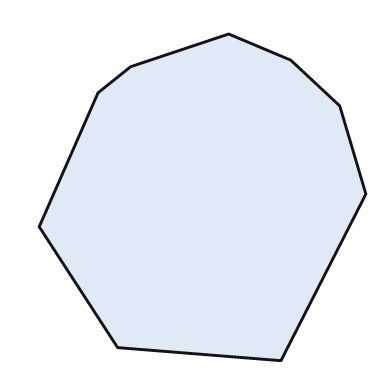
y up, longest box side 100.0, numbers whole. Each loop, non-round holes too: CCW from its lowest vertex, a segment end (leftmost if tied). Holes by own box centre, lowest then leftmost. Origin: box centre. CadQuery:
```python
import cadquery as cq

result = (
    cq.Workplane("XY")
    .moveTo(24.0, -50.0)
    .lineTo(50.0, 1.0)
    .lineTo(42.0, 28.0)
    .lineTo(27.0, 42.0)
    .lineTo(8.0, 50.0)
    .lineTo(-22.0, 40.0)
    .lineTo(-32.0, 32.0)
    .lineTo(-50.0, -9.0)
    .lineTo(-26.0, -46.0)
    .close()
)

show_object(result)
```